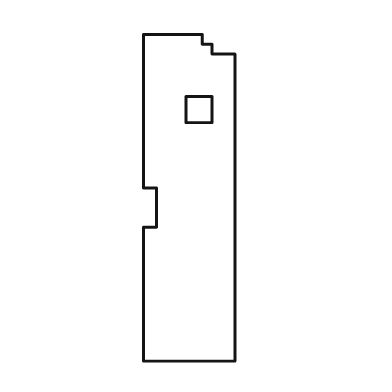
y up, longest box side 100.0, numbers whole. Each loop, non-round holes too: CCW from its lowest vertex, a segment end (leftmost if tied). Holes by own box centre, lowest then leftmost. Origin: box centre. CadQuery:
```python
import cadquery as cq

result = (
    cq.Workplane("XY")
    .moveTo(-14.0, -50.0)
    .lineTo(14.0, -50.0)
    .lineTo(14.0, 44.0)
    .lineTo(7.0, 44.0)
    .lineTo(7.0, 47.0)
    .lineTo(4.0, 47.0)
    .lineTo(4.0, 50.0)
    .lineTo(-14.0, 50.0)
    .lineTo(-14.0, 3.0)
    .lineTo(-10.0, 3.0)
    .lineTo(-10.0, -9.0)
    .lineTo(-14.0, -9.0)
    .close()
    .moveTo(-1.0, 23.0)
    .lineTo(7.0, 23.0)
    .lineTo(7.0, 31.0)
    .lineTo(-1.0, 31.0)
    .close()
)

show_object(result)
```